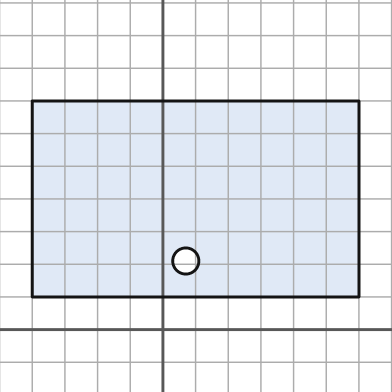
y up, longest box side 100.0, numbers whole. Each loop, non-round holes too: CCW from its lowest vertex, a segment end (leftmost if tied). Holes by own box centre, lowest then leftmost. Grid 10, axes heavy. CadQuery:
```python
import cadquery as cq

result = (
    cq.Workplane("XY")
    .moveTo(-40.0, 10.0)
    .lineTo(60.0, 10.0)
    .lineTo(60.0, 70.0)
    .lineTo(-40.0, 70.0)
    .close()
    .moveTo(7.0, 21.0)
    .circle(4.0)
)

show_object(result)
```